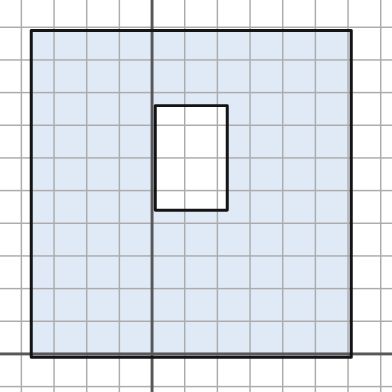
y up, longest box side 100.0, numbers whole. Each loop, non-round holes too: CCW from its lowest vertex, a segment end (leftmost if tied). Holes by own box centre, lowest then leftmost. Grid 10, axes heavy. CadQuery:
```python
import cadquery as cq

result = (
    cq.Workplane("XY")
    .moveTo(-37.0, -1.0)
    .lineTo(61.0, -1.0)
    .lineTo(61.0, 99.0)
    .lineTo(-37.0, 99.0)
    .close()
    .moveTo(1.0, 44.0)
    .lineTo(23.0, 44.0)
    .lineTo(23.0, 76.0)
    .lineTo(1.0, 76.0)
    .close()
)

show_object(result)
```